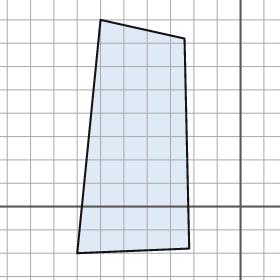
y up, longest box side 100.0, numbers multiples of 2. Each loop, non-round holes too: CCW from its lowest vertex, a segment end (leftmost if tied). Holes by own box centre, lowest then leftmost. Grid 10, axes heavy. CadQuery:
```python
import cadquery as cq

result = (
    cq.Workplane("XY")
    .moveTo(-70.0, -20.0)
    .lineTo(-22.0, -18.0)
    .lineTo(-24.0, 72.0)
    .lineTo(-60.0, 80.0)
    .close()
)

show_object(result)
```